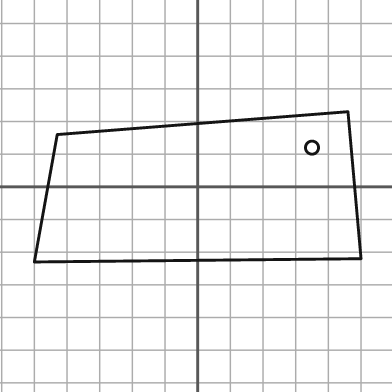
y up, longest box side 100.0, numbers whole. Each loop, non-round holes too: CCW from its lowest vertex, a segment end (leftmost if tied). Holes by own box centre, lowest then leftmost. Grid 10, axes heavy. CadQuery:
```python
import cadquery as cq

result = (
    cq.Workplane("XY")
    .moveTo(-50.0, -23.0)
    .lineTo(50.0, -22.0)
    .lineTo(46.0, 23.0)
    .lineTo(-43.0, 16.0)
    .close()
    .moveTo(35.0, 12.0)
    .circle(2.0)
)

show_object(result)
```